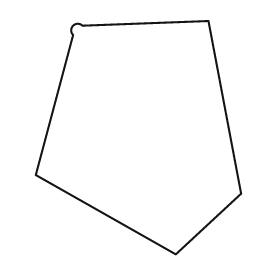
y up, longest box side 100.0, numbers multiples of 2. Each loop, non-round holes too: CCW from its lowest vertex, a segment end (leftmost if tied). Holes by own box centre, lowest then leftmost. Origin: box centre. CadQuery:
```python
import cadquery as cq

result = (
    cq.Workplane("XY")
    .moveTo(16.0, -50.0)
    .lineTo(44.0, -24.0)
    .lineTo(30.0, 50.0)
    .lineTo(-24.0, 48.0)
    .threePointArc((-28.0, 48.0), (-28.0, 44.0))
    .lineTo(-44.0, -16.0)
    .close()
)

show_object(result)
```